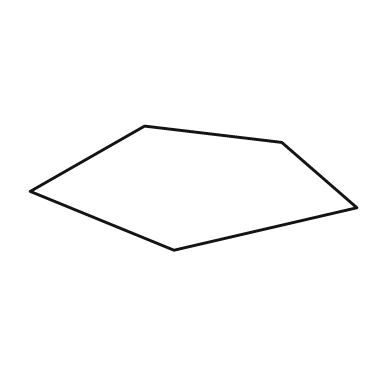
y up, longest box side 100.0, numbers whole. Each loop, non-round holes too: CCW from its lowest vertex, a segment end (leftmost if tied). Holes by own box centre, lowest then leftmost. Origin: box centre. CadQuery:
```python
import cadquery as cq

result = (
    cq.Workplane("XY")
    .moveTo(-6.0, -19.0)
    .lineTo(50.0, -6.0)
    .lineTo(27.0, 14.0)
    .lineTo(-15.0, 19.0)
    .lineTo(-50.0, -1.0)
    .close()
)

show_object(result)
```